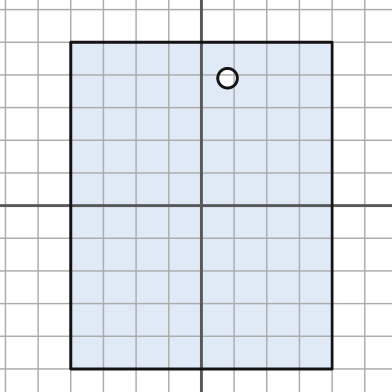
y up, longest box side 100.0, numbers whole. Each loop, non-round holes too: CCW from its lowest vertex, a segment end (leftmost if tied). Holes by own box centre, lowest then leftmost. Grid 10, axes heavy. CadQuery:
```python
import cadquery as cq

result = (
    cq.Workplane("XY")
    .moveTo(-40.0, -50.0)
    .lineTo(40.0, -50.0)
    .lineTo(40.0, 50.0)
    .lineTo(-40.0, 50.0)
    .close()
    .moveTo(8.0, 39.0)
    .circle(3.0)
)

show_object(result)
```